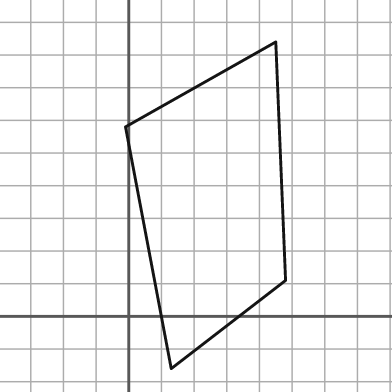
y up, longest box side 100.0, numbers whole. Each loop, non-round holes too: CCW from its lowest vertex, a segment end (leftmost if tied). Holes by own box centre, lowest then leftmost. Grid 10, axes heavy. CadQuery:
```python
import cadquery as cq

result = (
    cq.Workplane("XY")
    .moveTo(13.0, -16.0)
    .lineTo(48.0, 11.0)
    .lineTo(45.0, 84.0)
    .lineTo(-1.0, 58.0)
    .close()
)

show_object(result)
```